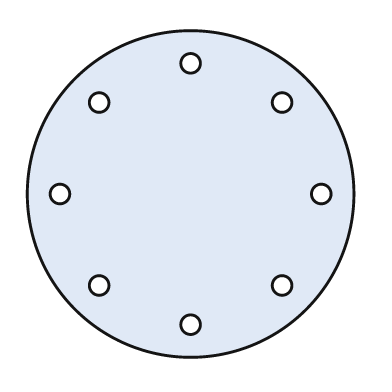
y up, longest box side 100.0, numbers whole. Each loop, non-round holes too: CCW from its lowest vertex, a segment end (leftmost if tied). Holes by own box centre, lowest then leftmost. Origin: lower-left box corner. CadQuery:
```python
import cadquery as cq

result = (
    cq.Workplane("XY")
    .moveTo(50.0, 50.0)
    .circle(50.0)
    .moveTo(50.0, 10.0)
    .circle(3.0)
    .moveTo(22.0, 22.0)
    .circle(3.0)
    .moveTo(78.0, 22.0)
    .circle(3.0)
    .moveTo(10.0, 50.0)
    .circle(3.0)
    .moveTo(90.0, 50.0)
    .circle(3.0)
    .moveTo(22.0, 78.0)
    .circle(3.0)
    .moveTo(78.0, 78.0)
    .circle(3.0)
    .moveTo(50.0, 90.0)
    .circle(3.0)
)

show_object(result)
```